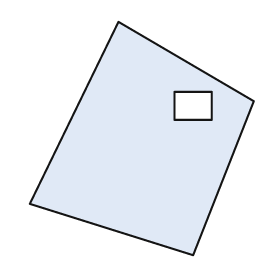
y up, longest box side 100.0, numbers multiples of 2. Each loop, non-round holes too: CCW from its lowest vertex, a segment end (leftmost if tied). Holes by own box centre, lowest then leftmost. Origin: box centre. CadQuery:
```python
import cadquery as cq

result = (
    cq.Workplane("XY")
    .moveTo(22.0, -50.0)
    .lineTo(48.0, 16.0)
    .lineTo(-10.0, 50.0)
    .lineTo(-48.0, -28.0)
    .close()
    .moveTo(14.0, 8.0)
    .lineTo(30.0, 8.0)
    .lineTo(30.0, 20.0)
    .lineTo(14.0, 20.0)
    .close()
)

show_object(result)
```